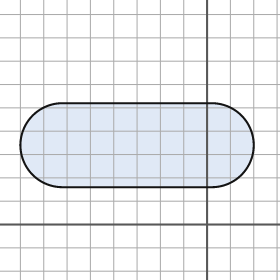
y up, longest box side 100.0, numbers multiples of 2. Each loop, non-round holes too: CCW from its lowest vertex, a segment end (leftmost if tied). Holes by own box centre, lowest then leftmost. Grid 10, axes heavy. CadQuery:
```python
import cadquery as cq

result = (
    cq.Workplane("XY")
    .moveTo(-62.0, 16.0)
    .lineTo(2.0, 16.0)
    .threePointArc((20.0, 34.0), (2.0, 52.0))
    .lineTo(-62.0, 52.0)
    .threePointArc((-80.0, 34.0), (-62.0, 16.0))
    .close()
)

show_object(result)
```